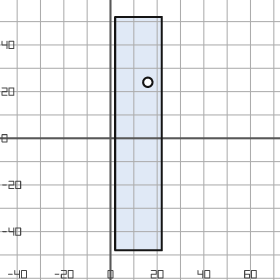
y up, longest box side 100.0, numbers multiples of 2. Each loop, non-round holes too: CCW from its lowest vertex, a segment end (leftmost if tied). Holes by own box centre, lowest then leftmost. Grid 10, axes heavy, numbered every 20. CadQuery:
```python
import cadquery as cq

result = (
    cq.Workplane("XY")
    .moveTo(2.0, -48.0)
    .lineTo(22.0, -48.0)
    .lineTo(22.0, 52.0)
    .lineTo(2.0, 52.0)
    .close()
    .moveTo(16.0, 24.0)
    .circle(2.0)
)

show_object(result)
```